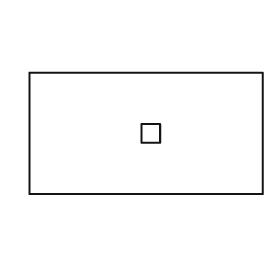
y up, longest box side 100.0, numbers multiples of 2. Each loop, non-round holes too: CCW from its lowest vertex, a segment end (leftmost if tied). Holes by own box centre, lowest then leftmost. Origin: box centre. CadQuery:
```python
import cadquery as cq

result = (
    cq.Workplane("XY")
    .moveTo(-50.0, -26.0)
    .lineTo(50.0, -26.0)
    .lineTo(50.0, 26.0)
    .lineTo(-50.0, 26.0)
    .close()
    .moveTo(-2.0, -4.0)
    .lineTo(6.0, -4.0)
    .lineTo(6.0, 4.0)
    .lineTo(-2.0, 4.0)
    .close()
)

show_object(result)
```